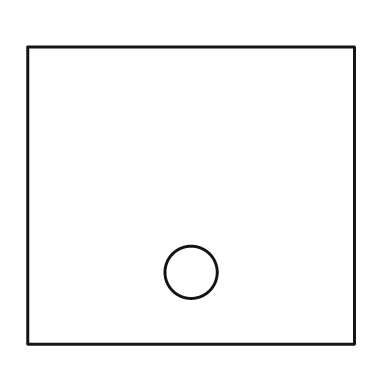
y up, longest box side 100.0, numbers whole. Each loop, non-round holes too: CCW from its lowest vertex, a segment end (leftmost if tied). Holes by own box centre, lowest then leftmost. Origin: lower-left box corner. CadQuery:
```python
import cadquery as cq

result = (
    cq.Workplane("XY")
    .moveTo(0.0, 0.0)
    .lineTo(100.0, 0.0)
    .lineTo(100.0, 91.0)
    .lineTo(0.0, 91.0)
    .close()
    .moveTo(50.0, 22.0)
    .circle(8.0)
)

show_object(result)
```